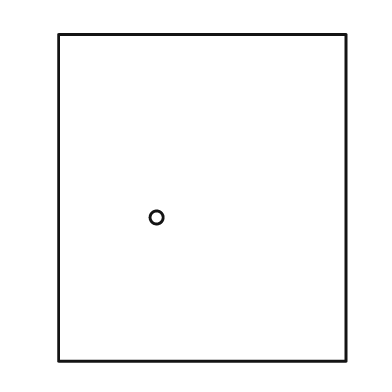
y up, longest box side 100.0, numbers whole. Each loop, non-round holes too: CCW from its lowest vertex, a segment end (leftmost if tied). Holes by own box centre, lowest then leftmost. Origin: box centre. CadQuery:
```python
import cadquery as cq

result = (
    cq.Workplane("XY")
    .moveTo(-44.0, -50.0)
    .lineTo(44.0, -50.0)
    .lineTo(44.0, 50.0)
    .lineTo(-44.0, 50.0)
    .close()
    .moveTo(-14.0, -6.0)
    .circle(2.0)
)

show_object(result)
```